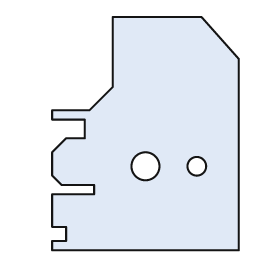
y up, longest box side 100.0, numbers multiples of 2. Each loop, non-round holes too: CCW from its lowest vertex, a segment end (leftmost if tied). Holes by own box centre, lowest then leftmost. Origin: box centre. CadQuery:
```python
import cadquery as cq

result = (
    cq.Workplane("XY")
    .moveTo(-40.0, -50.0)
    .lineTo(40.0, -50.0)
    .lineTo(40.0, 32.0)
    .lineTo(24.0, 50.0)
    .lineTo(-14.0, 50.0)
    .lineTo(-14.0, 20.0)
    .lineTo(-24.0, 10.0)
    .lineTo(-40.0, 10.0)
    .lineTo(-40.0, 6.0)
    .lineTo(-26.0, 6.0)
    .lineTo(-26.0, -2.0)
    .lineTo(-34.0, -2.0)
    .lineTo(-40.0, -8.0)
    .lineTo(-40.0, -18.0)
    .lineTo(-36.0, -22.0)
    .lineTo(-22.0, -22.0)
    .lineTo(-22.0, -26.0)
    .lineTo(-40.0, -26.0)
    .lineTo(-40.0, -40.0)
    .lineTo(-34.0, -40.0)
    .lineTo(-34.0, -46.0)
    .lineTo(-40.0, -46.0)
    .close()
    .moveTo(0.0, -14.0)
    .circle(6.0)
    .moveTo(22.0, -14.0)
    .circle(4.0)
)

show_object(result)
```